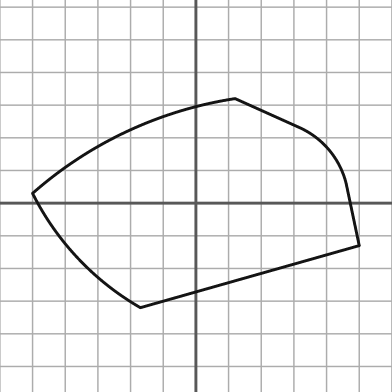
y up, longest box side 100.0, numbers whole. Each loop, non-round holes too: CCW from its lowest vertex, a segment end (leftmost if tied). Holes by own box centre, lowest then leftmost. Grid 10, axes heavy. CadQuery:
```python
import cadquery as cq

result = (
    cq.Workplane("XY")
    .moveTo(-17.0, -32.0)
    .lineTo(50.0, -13.0)
    .lineTo(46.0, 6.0)
    .threePointArc((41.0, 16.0), (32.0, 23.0))
    .lineTo(12.0, 32.0)
    .threePointArc((-21.0, 22.0), (-50.0, 3.0))
    .threePointArc((-36.0, -17.0), (-17.0, -32.0))
    .close()
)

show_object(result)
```